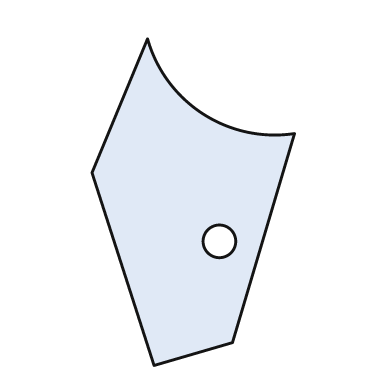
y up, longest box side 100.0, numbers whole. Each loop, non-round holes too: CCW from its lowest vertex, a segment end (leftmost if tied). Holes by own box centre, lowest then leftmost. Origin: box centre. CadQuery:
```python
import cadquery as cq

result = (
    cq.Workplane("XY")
    .moveTo(-12.0, -50.0)
    .lineTo(12.0, -43.0)
    .lineTo(31.0, 21.0)
    .threePointArc((3.0, 27.0), (-14.0, 50.0))
    .lineTo(-31.0, 9.0)
    .close()
    .moveTo(8.0, -12.0)
    .circle(5.0)
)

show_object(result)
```